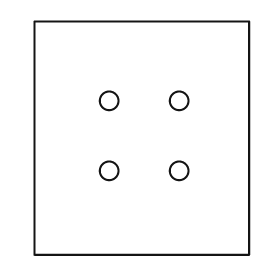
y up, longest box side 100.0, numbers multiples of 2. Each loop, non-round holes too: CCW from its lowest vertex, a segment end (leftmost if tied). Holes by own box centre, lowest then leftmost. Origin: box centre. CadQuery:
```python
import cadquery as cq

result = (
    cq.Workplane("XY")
    .moveTo(-46.0, -50.0)
    .lineTo(46.0, -50.0)
    .lineTo(46.0, 50.0)
    .lineTo(-46.0, 50.0)
    .close()
    .moveTo(-14.0, -14.0)
    .circle(4.0)
    .moveTo(16.0, -14.0)
    .circle(4.0)
    .moveTo(-14.0, 16.0)
    .circle(4.0)
    .moveTo(16.0, 16.0)
    .circle(4.0)
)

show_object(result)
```